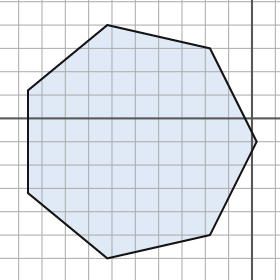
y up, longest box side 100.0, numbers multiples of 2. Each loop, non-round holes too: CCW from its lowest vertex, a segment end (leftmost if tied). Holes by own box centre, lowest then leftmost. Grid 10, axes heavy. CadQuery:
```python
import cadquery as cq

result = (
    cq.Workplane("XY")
    .moveTo(-62.0, -60.0)
    .lineTo(-18.0, -50.0)
    .lineTo(2.0, -10.0)
    .lineTo(-18.0, 30.0)
    .lineTo(-62.0, 40.0)
    .lineTo(-96.0, 12.0)
    .lineTo(-96.0, -32.0)
    .close()
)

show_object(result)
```